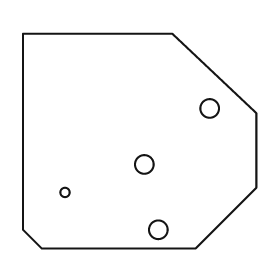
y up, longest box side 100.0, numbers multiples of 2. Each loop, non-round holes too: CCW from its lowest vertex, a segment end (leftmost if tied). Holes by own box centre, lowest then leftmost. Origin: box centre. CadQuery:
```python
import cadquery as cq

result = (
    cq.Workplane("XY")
    .moveTo(-42.0, -46.0)
    .lineTo(24.0, -46.0)
    .lineTo(50.0, -20.0)
    .lineTo(50.0, 12.0)
    .lineTo(14.0, 46.0)
    .lineTo(-50.0, 46.0)
    .lineTo(-50.0, -38.0)
    .close()
    .moveTo(8.0, -38.0)
    .circle(4.0)
    .moveTo(-32.0, -22.0)
    .circle(2.0)
    .moveTo(2.0, -10.0)
    .circle(4.0)
    .moveTo(30.0, 14.0)
    .circle(4.0)
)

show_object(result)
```